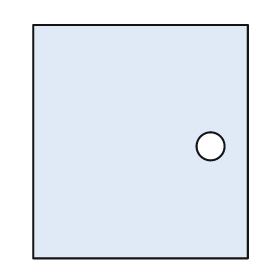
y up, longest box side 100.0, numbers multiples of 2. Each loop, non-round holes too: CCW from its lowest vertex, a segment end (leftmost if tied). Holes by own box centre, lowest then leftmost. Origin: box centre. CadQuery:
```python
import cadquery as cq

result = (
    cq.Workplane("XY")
    .moveTo(-46.0, -50.0)
    .lineTo(46.0, -50.0)
    .lineTo(46.0, 50.0)
    .lineTo(-46.0, 50.0)
    .close()
    .moveTo(30.0, -2.0)
    .circle(6.0)
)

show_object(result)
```